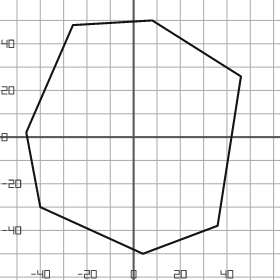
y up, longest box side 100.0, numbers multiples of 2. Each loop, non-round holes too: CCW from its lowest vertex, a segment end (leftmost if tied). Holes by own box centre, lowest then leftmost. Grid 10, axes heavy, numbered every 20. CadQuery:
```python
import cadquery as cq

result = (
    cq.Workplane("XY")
    .moveTo(4.0, -50.0)
    .lineTo(36.0, -38.0)
    .lineTo(46.0, 26.0)
    .lineTo(8.0, 50.0)
    .lineTo(-26.0, 48.0)
    .lineTo(-46.0, 2.0)
    .lineTo(-40.0, -30.0)
    .close()
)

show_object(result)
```